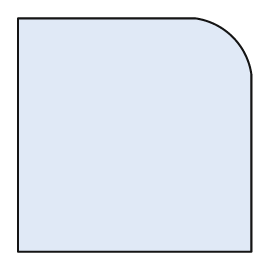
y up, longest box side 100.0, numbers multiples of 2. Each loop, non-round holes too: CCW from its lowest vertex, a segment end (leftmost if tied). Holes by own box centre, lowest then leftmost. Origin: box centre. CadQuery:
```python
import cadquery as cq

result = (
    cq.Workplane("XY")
    .moveTo(-50.0, -50.0)
    .lineTo(50.0, -50.0)
    .lineTo(50.0, 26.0)
    .threePointArc((42.0, 42.0), (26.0, 50.0))
    .lineTo(-50.0, 50.0)
    .close()
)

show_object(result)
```